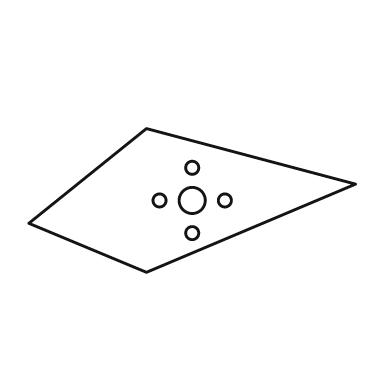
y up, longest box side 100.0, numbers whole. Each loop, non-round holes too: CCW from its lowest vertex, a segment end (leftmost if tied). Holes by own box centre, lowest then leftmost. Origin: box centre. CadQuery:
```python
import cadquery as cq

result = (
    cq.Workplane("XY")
    .moveTo(-14.0, -22.0)
    .lineTo(50.0, 5.0)
    .lineTo(-14.0, 22.0)
    .lineTo(-50.0, -7.0)
    .close()
    .moveTo(0.0, -10.0)
    .circle(2.0)
    .moveTo(-10.0, 0.0)
    .circle(2.0)
    .moveTo(0.0, 0.0)
    .circle(4.0)
    .moveTo(10.0, 0.0)
    .circle(2.0)
    .moveTo(0.0, 10.0)
    .circle(2.0)
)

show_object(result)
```